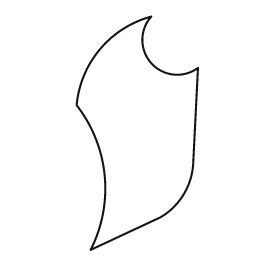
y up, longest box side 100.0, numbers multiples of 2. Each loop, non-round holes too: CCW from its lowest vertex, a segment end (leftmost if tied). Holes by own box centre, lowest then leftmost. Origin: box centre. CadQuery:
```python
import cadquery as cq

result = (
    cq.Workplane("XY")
    .moveTo(-20.0, -50.0)
    .lineTo(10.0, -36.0)
    .threePointArc((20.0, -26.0), (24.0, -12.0))
    .lineTo(26.0, 28.0)
    .threePointArc((6.0, 30.0), (6.0, 50.0))
    .threePointArc((-16.0, 36.0), (-26.0, 12.0))
    .threePointArc((-14.0, -18.0), (-20.0, -50.0))
    .close()
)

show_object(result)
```